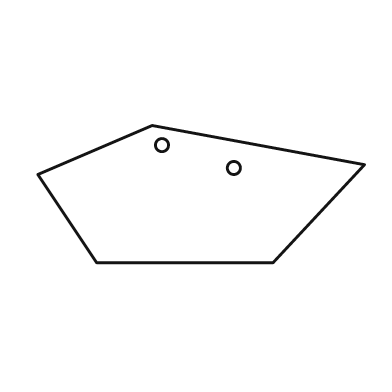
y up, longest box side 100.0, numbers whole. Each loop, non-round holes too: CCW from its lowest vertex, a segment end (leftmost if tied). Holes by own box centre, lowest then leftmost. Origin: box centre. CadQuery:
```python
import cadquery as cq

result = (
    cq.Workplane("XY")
    .moveTo(-32.0, -21.0)
    .lineTo(22.0, -21.0)
    .lineTo(50.0, 9.0)
    .lineTo(-15.0, 21.0)
    .lineTo(-50.0, 6.0)
    .close()
    .moveTo(10.0, 8.0)
    .circle(2.0)
    .moveTo(-12.0, 15.0)
    .circle(2.0)
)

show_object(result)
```